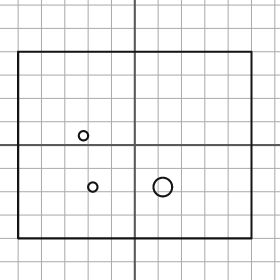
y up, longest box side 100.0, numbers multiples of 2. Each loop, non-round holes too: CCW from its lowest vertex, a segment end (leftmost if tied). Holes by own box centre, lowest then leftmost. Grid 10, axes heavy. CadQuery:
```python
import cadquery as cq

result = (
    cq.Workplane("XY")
    .moveTo(-50.0, -40.0)
    .lineTo(50.0, -40.0)
    .lineTo(50.0, 40.0)
    .lineTo(-50.0, 40.0)
    .close()
    .moveTo(-18.0, -18.0)
    .circle(2.0)
    .moveTo(12.0, -18.0)
    .circle(4.0)
    .moveTo(-22.0, 4.0)
    .circle(2.0)
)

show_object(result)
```